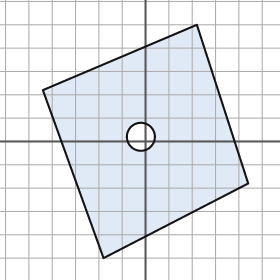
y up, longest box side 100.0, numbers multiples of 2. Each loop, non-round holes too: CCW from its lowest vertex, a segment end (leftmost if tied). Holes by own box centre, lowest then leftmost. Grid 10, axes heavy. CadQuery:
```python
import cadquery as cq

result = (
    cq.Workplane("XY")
    .moveTo(-18.0, -50.0)
    .lineTo(44.0, -18.0)
    .lineTo(22.0, 50.0)
    .lineTo(-44.0, 22.0)
    .close()
    .moveTo(-2.0, 2.0)
    .circle(6.0)
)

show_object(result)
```